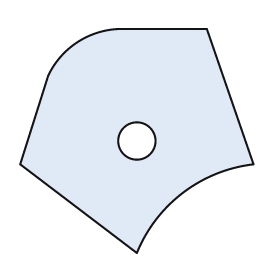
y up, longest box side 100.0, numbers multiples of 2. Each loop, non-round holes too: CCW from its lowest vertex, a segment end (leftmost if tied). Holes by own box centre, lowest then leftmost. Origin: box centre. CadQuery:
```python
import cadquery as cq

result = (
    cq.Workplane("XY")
    .moveTo(0.0, -48.0)
    .threePointArc((20.0, -22.0), (50.0, -10.0))
    .lineTo(30.0, 48.0)
    .lineTo(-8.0, 48.0)
    .threePointArc((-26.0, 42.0), (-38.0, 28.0))
    .lineTo(-50.0, -10.0)
    .close()
    .moveTo(0.0, 0.0)
    .circle(8.0)
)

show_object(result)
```